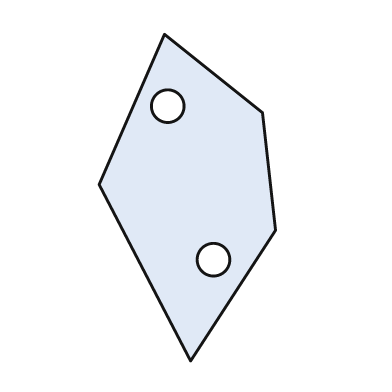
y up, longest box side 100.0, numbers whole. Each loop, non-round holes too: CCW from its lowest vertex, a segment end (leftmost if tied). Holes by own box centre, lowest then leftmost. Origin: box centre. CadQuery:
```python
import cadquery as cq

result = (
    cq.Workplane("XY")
    .moveTo(1.0, -50.0)
    .lineTo(27.0, -10.0)
    .lineTo(23.0, 26.0)
    .lineTo(-7.0, 50.0)
    .lineTo(-27.0, 4.0)
    .close()
    .moveTo(8.0, -19.0)
    .circle(5.0)
    .moveTo(-6.0, 28.0)
    .circle(5.0)
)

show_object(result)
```